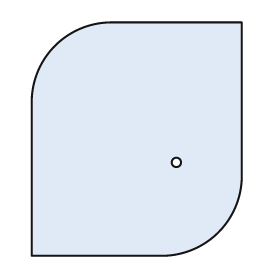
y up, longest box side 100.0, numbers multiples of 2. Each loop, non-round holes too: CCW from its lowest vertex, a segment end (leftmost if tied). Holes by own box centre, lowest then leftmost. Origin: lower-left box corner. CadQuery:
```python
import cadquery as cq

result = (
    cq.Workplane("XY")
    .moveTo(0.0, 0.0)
    .lineTo(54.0, 0.0)
    .threePointArc((80.0, 10.0), (90.0, 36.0))
    .lineTo(90.0, 100.0)
    .lineTo(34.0, 100.0)
    .threePointArc((10.0, 90.0), (0.0, 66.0))
    .close()
    .moveTo(62.0, 40.0)
    .circle(2.0)
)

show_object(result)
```